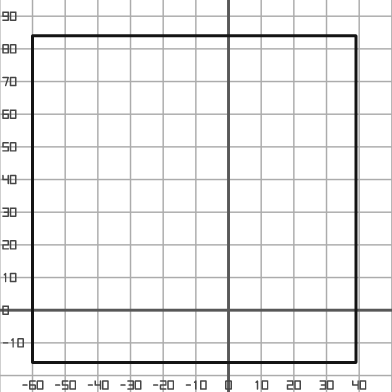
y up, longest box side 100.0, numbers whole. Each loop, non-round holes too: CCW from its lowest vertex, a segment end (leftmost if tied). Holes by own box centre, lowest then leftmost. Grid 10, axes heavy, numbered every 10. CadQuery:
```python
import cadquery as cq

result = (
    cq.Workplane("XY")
    .moveTo(-60.0, -16.0)
    .lineTo(39.0, -16.0)
    .lineTo(39.0, 84.0)
    .lineTo(-60.0, 84.0)
    .close()
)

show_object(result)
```